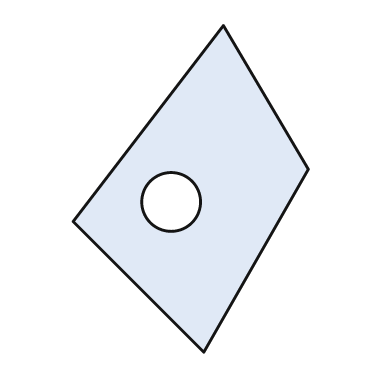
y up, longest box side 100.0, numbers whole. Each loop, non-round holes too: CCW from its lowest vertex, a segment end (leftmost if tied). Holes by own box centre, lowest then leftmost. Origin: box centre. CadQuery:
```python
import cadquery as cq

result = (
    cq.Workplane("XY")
    .moveTo(4.0, -50.0)
    .lineTo(36.0, 6.0)
    .lineTo(10.0, 50.0)
    .lineTo(-36.0, -10.0)
    .close()
    .moveTo(-6.0, -4.0)
    .circle(9.0)
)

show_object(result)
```